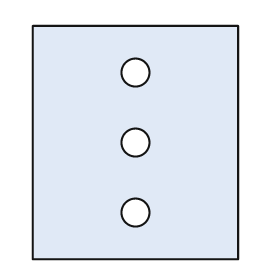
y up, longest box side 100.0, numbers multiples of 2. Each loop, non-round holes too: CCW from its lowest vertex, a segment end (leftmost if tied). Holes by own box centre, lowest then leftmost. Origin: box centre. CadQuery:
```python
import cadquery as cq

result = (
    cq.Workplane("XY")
    .moveTo(-44.0, -50.0)
    .lineTo(44.0, -50.0)
    .lineTo(44.0, 50.0)
    .lineTo(-44.0, 50.0)
    .close()
    .moveTo(0.0, -30.0)
    .circle(6.0)
    .moveTo(0.0, 0.0)
    .circle(6.0)
    .moveTo(0.0, 30.0)
    .circle(6.0)
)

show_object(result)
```